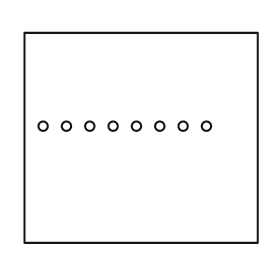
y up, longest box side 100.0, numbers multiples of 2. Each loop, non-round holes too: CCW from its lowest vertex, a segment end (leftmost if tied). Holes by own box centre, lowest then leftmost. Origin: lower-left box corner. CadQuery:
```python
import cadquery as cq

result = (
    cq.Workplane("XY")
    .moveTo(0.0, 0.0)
    .lineTo(100.0, 0.0)
    .lineTo(100.0, 90.0)
    .lineTo(0.0, 90.0)
    .close()
    .moveTo(8.0, 50.0)
    .circle(2.0)
    .moveTo(18.0, 50.0)
    .circle(2.0)
    .moveTo(28.0, 50.0)
    .circle(2.0)
    .moveTo(38.0, 50.0)
    .circle(2.0)
    .moveTo(48.0, 50.0)
    .circle(2.0)
    .moveTo(58.0, 50.0)
    .circle(2.0)
    .moveTo(68.0, 50.0)
    .circle(2.0)
    .moveTo(78.0, 50.0)
    .circle(2.0)
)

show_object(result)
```